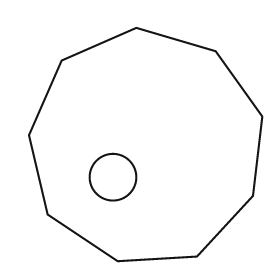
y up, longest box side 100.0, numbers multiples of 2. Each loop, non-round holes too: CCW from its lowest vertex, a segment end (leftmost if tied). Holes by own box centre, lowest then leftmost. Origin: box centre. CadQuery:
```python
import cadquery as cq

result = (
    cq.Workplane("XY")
    .moveTo(-12.0, -50.0)
    .lineTo(22.0, -48.0)
    .lineTo(46.0, -22.0)
    .lineTo(50.0, 12.0)
    .lineTo(30.0, 40.0)
    .lineTo(-4.0, 50.0)
    .lineTo(-36.0, 36.0)
    .lineTo(-50.0, 4.0)
    .lineTo(-42.0, -30.0)
    .close()
    .moveTo(-14.0, -14.0)
    .circle(10.0)
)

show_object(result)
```